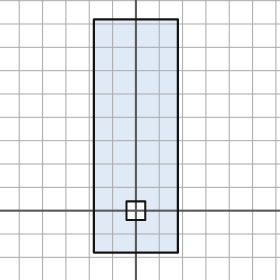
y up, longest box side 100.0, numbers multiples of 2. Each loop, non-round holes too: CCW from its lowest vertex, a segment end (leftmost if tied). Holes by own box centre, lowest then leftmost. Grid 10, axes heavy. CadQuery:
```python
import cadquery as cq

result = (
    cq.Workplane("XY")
    .moveTo(-18.0, -18.0)
    .lineTo(18.0, -18.0)
    .lineTo(18.0, 82.0)
    .lineTo(-18.0, 82.0)
    .close()
    .moveTo(-4.0, -4.0)
    .lineTo(4.0, -4.0)
    .lineTo(4.0, 4.0)
    .lineTo(-4.0, 4.0)
    .close()
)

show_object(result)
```